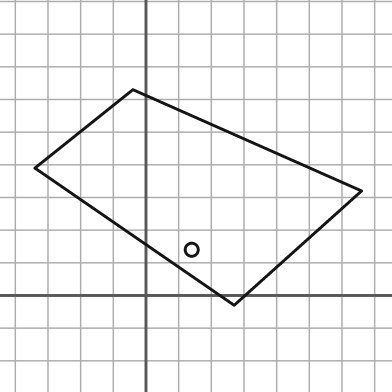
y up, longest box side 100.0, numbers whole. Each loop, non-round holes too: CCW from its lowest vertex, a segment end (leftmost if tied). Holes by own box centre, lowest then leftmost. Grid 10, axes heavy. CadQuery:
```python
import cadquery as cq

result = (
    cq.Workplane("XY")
    .moveTo(27.0, -3.0)
    .lineTo(66.0, 32.0)
    .lineTo(-4.0, 63.0)
    .lineTo(-34.0, 39.0)
    .close()
    .moveTo(14.0, 14.0)
    .circle(2.0)
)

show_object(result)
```